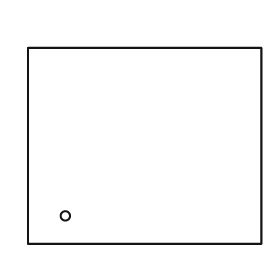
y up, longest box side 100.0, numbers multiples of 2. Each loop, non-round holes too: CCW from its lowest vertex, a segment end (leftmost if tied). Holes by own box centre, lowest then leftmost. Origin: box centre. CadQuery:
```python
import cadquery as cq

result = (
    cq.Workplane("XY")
    .moveTo(-50.0, -42.0)
    .lineTo(50.0, -42.0)
    .lineTo(50.0, 42.0)
    .lineTo(-50.0, 42.0)
    .close()
    .moveTo(-34.0, -30.0)
    .circle(2.0)
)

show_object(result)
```